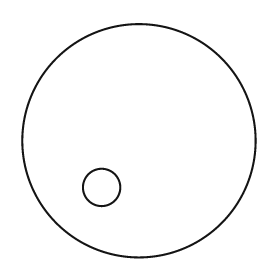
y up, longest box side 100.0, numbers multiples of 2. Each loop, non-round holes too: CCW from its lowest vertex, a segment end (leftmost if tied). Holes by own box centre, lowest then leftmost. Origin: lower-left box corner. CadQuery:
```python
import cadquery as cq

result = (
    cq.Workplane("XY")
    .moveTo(50.0, 50.0)
    .circle(50.0)
    .moveTo(34.0, 30.0)
    .circle(8.0)
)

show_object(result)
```